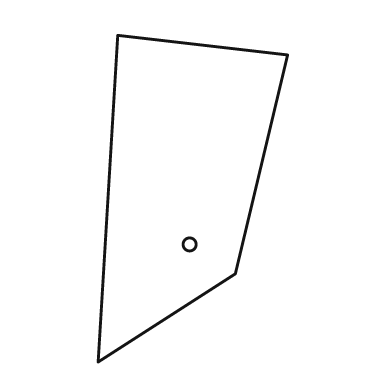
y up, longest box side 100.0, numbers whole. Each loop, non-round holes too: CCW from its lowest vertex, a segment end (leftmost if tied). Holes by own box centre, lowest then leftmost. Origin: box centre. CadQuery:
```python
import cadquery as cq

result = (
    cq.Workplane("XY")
    .moveTo(-29.0, -50.0)
    .lineTo(13.0, -23.0)
    .lineTo(29.0, 44.0)
    .lineTo(-23.0, 50.0)
    .close()
    .moveTo(-1.0, -14.0)
    .circle(2.0)
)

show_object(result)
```